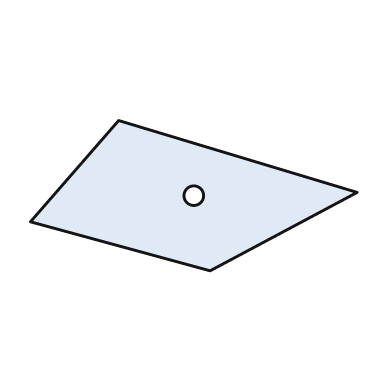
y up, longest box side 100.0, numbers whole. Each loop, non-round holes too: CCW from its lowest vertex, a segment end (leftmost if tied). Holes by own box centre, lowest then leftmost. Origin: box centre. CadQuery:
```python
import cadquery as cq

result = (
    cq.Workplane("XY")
    .moveTo(5.0, -23.0)
    .lineTo(50.0, 1.0)
    .lineTo(-23.0, 23.0)
    .lineTo(-50.0, -8.0)
    .close()
    .moveTo(0.0, 0.0)
    .circle(3.0)
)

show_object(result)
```